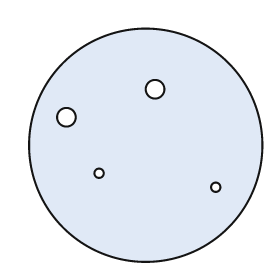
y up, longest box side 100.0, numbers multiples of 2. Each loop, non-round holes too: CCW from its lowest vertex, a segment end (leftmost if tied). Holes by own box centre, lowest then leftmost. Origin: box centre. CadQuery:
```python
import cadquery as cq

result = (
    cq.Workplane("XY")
    .moveTo(0.0, 0.0)
    .circle(50.0)
    .moveTo(30.0, -18.0)
    .circle(2.0)
    .moveTo(-20.0, -12.0)
    .circle(2.0)
    .moveTo(-34.0, 12.0)
    .circle(4.0)
    .moveTo(4.0, 24.0)
    .circle(4.0)
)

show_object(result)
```